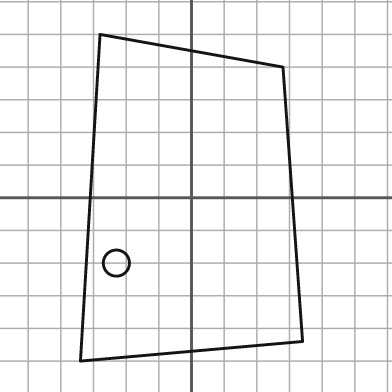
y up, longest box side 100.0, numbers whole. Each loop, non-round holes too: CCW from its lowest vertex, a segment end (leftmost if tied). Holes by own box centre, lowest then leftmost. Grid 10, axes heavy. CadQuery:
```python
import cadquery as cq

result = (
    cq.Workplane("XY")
    .moveTo(-34.0, -50.0)
    .lineTo(34.0, -44.0)
    .lineTo(28.0, 40.0)
    .lineTo(-28.0, 50.0)
    .close()
    .moveTo(-23.0, -20.0)
    .circle(4.0)
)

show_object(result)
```